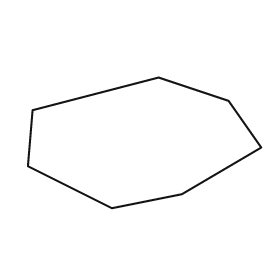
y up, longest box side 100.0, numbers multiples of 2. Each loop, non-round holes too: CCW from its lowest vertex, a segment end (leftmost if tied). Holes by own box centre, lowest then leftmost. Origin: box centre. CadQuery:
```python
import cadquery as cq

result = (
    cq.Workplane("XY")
    .moveTo(-14.0, -28.0)
    .lineTo(16.0, -22.0)
    .lineTo(50.0, -2.0)
    .lineTo(36.0, 18.0)
    .lineTo(6.0, 28.0)
    .lineTo(-48.0, 14.0)
    .lineTo(-50.0, -10.0)
    .close()
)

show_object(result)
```